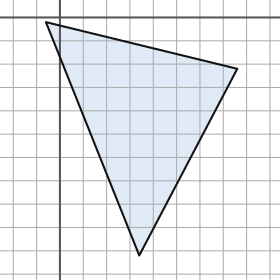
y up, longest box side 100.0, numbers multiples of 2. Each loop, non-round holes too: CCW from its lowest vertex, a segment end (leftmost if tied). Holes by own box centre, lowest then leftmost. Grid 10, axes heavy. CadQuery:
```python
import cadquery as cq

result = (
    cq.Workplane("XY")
    .moveTo(34.0, -102.0)
    .lineTo(76.0, -22.0)
    .lineTo(-6.0, -2.0)
    .close()
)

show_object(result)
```